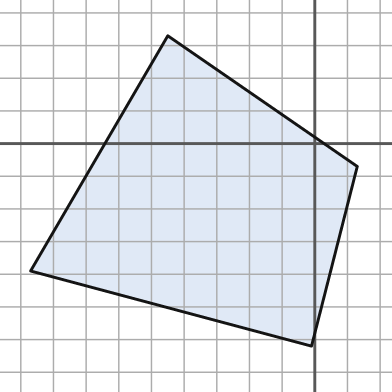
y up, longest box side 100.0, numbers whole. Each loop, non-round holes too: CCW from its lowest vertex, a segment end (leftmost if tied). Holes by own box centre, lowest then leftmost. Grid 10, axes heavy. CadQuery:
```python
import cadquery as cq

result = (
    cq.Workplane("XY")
    .moveTo(-1.0, -62.0)
    .lineTo(13.0, -7.0)
    .lineTo(-45.0, 33.0)
    .lineTo(-87.0, -39.0)
    .close()
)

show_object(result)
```